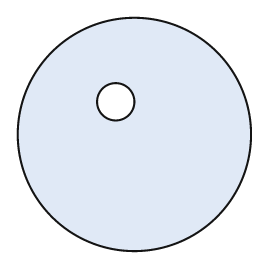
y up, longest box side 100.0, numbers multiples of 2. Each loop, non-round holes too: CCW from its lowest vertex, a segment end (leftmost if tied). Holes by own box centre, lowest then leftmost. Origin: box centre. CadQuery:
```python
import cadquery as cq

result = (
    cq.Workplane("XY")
    .moveTo(0.0, 0.0)
    .circle(50.0)
    .moveTo(-8.0, 14.0)
    .circle(8.0)
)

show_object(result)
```